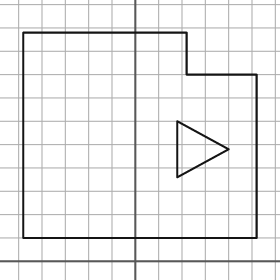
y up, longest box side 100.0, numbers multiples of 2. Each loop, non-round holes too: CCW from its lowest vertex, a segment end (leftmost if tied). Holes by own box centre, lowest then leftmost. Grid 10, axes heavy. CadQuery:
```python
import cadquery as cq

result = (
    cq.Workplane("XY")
    .moveTo(-48.0, 10.0)
    .lineTo(52.0, 10.0)
    .lineTo(52.0, 80.0)
    .lineTo(22.0, 80.0)
    .lineTo(22.0, 98.0)
    .lineTo(-48.0, 98.0)
    .close()
    .moveTo(18.0, 36.0)
    .lineTo(40.0, 48.0)
    .lineTo(18.0, 60.0)
    .close()
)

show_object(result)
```